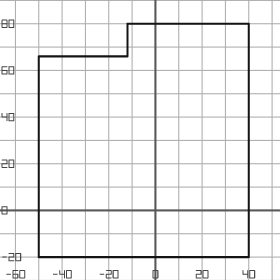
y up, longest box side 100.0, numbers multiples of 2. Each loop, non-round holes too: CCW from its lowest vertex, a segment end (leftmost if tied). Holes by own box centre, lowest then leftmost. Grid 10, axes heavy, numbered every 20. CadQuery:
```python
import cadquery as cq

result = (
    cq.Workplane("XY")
    .moveTo(-50.0, -20.0)
    .lineTo(40.0, -20.0)
    .lineTo(40.0, 80.0)
    .lineTo(-12.0, 80.0)
    .lineTo(-12.0, 66.0)
    .lineTo(-50.0, 66.0)
    .close()
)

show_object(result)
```